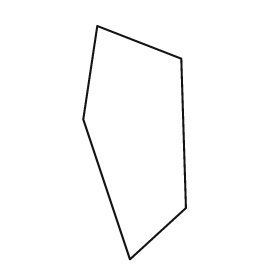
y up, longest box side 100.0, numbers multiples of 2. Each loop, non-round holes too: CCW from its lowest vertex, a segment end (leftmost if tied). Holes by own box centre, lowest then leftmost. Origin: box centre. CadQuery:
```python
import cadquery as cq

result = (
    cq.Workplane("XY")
    .moveTo(-2.0, -50.0)
    .lineTo(22.0, -28.0)
    .lineTo(20.0, 36.0)
    .lineTo(-16.0, 50.0)
    .lineTo(-22.0, 10.0)
    .close()
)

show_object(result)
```